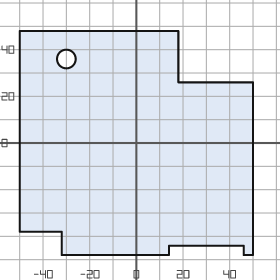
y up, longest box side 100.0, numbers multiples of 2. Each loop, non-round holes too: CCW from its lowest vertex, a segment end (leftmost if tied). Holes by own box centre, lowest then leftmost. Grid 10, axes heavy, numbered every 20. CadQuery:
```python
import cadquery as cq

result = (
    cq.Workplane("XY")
    .moveTo(-32.0, -48.0)
    .lineTo(14.0, -48.0)
    .lineTo(14.0, -44.0)
    .lineTo(46.0, -44.0)
    .lineTo(46.0, -48.0)
    .lineTo(50.0, -48.0)
    .lineTo(50.0, 26.0)
    .lineTo(18.0, 26.0)
    .lineTo(18.0, 48.0)
    .lineTo(-50.0, 48.0)
    .lineTo(-50.0, -38.0)
    .lineTo(-32.0, -38.0)
    .close()
    .moveTo(-30.0, 36.0)
    .circle(4.0)
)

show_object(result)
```